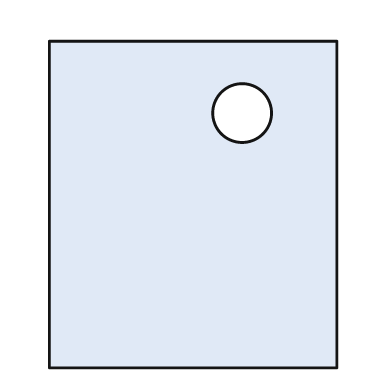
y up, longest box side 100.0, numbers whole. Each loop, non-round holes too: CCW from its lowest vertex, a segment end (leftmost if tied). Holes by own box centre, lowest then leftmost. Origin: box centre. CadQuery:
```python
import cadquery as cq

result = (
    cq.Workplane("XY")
    .moveTo(-44.0, -50.0)
    .lineTo(44.0, -50.0)
    .lineTo(44.0, 50.0)
    .lineTo(-44.0, 50.0)
    .close()
    .moveTo(15.0, 28.0)
    .circle(9.0)
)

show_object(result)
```